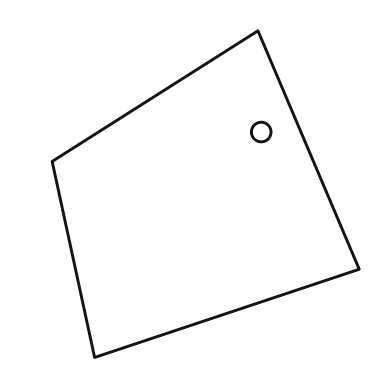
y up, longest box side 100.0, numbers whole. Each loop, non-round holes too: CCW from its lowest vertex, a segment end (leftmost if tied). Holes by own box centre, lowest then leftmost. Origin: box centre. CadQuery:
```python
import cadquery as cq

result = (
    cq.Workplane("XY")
    .moveTo(-34.0, -50.0)
    .lineTo(47.0, -23.0)
    .lineTo(16.0, 50.0)
    .lineTo(-47.0, 10.0)
    .close()
    .moveTo(17.0, 19.0)
    .circle(3.0)
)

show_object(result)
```